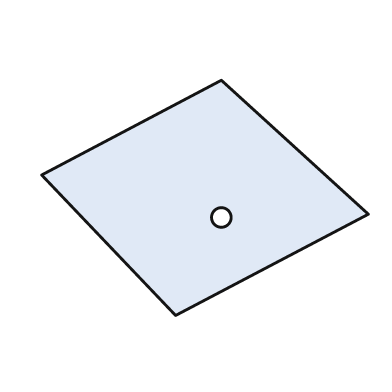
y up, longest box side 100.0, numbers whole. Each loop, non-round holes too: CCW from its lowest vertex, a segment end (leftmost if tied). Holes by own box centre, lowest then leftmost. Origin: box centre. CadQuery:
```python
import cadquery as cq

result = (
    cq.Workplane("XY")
    .moveTo(-9.0, -36.0)
    .lineTo(50.0, -5.0)
    .lineTo(5.0, 36.0)
    .lineTo(-50.0, 7.0)
    .close()
    .moveTo(5.0, -6.0)
    .circle(3.0)
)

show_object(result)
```